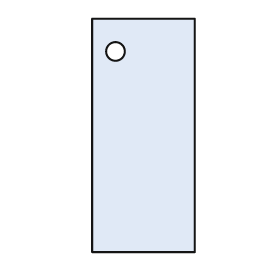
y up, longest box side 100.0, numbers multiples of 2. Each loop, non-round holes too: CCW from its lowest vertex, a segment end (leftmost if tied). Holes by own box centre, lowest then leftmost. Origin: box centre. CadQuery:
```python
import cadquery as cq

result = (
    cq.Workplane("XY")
    .moveTo(-22.0, -50.0)
    .lineTo(22.0, -50.0)
    .lineTo(22.0, 50.0)
    .lineTo(-22.0, 50.0)
    .close()
    .moveTo(-12.0, 36.0)
    .circle(4.0)
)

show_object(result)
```